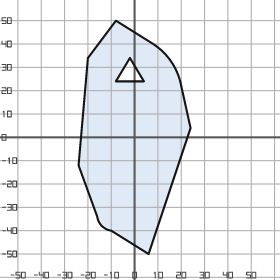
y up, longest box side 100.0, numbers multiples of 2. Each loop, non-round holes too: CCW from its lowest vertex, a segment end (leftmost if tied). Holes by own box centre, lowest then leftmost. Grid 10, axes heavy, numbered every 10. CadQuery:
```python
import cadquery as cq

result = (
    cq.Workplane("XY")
    .moveTo(6.0, -50.0)
    .lineTo(24.0, 4.0)
    .lineTo(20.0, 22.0)
    .threePointArc((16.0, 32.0), (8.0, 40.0))
    .lineTo(-8.0, 50.0)
    .lineTo(-20.0, 34.0)
    .lineTo(-24.0, -12.0)
    .lineTo(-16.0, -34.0)
    .threePointArc((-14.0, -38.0), (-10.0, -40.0))
    .close()
    .moveTo(-8.0, 24.0)
    .lineTo(4.0, 24.0)
    .lineTo(-2.0, 34.0)
    .close()
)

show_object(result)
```